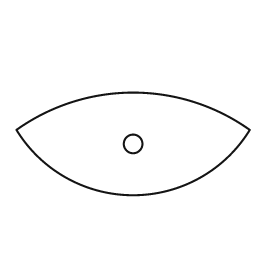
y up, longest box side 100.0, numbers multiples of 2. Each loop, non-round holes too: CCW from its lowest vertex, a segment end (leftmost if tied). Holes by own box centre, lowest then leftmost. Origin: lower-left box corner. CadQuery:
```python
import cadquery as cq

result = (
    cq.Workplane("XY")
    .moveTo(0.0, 28.0)
    .threePointArc((50.0, 0.0), (100.0, 28.0))
    .threePointArc((50.0, 44.0), (0.0, 28.0))
    .close()
    .moveTo(50.0, 22.0)
    .circle(4.0)
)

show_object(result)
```